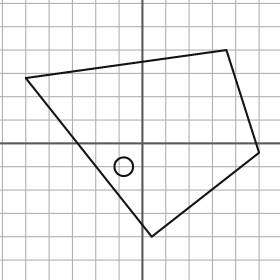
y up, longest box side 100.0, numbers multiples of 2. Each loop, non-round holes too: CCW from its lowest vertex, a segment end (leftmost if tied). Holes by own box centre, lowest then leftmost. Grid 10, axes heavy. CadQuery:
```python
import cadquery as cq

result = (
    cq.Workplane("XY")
    .moveTo(4.0, -40.0)
    .lineTo(50.0, -4.0)
    .lineTo(36.0, 40.0)
    .lineTo(-50.0, 28.0)
    .close()
    .moveTo(-8.0, -10.0)
    .circle(4.0)
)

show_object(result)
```